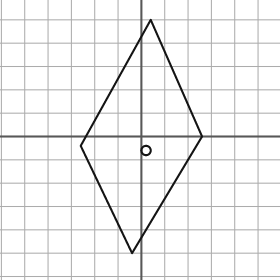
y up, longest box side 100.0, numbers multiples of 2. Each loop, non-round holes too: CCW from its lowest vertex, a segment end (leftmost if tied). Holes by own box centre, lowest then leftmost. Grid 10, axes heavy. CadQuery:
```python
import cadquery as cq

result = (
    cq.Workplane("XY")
    .moveTo(-4.0, -50.0)
    .lineTo(26.0, 0.0)
    .lineTo(4.0, 50.0)
    .lineTo(-26.0, -4.0)
    .close()
    .moveTo(2.0, -6.0)
    .circle(2.0)
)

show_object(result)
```